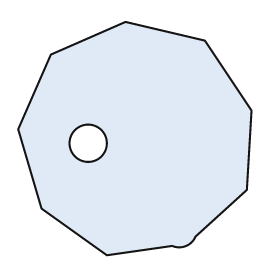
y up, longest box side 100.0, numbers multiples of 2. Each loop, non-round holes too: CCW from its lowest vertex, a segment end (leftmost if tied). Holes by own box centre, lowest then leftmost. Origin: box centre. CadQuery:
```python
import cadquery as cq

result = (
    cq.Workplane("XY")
    .moveTo(-12.0, -50.0)
    .lineTo(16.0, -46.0)
    .threePointArc((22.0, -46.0), (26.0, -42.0))
    .lineTo(48.0, -22.0)
    .lineTo(50.0, 12.0)
    .lineTo(30.0, 42.0)
    .lineTo(-4.0, 50.0)
    .lineTo(-36.0, 36.0)
    .lineTo(-50.0, 4.0)
    .lineTo(-40.0, -30.0)
    .close()
    .moveTo(-20.0, -2.0)
    .circle(8.0)
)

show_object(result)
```